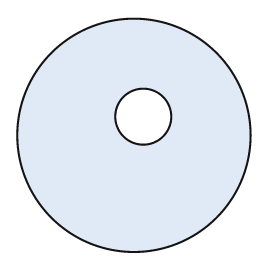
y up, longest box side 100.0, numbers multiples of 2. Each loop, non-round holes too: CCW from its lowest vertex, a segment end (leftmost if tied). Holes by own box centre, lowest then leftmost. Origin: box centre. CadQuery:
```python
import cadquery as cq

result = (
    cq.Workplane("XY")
    .moveTo(0.0, 0.0)
    .circle(50.0)
    .moveTo(4.0, 8.0)
    .circle(12.0)
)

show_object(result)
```